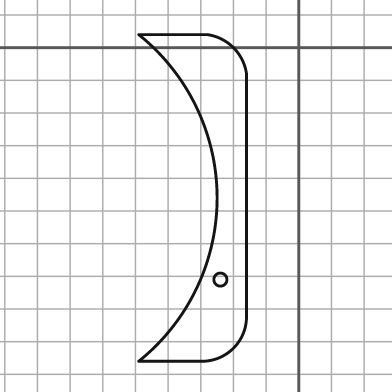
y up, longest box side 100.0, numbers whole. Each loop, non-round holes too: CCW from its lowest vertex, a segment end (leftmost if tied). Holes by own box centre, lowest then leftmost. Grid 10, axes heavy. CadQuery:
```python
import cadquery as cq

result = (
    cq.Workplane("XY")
    .moveTo(-49.0, -96.0)
    .lineTo(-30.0, -96.0)
    .threePointArc((-20.0, -92.0), (-16.0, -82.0))
    .lineTo(-16.0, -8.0)
    .threePointArc((-20.0, 0.0), (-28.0, 4.0))
    .lineTo(-49.0, 4.0)
    .threePointArc((-25.0, -46.0), (-49.0, -96.0))
    .close()
    .moveTo(-24.0, -71.0)
    .circle(2.0)
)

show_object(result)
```